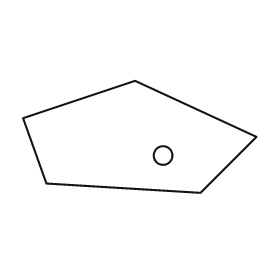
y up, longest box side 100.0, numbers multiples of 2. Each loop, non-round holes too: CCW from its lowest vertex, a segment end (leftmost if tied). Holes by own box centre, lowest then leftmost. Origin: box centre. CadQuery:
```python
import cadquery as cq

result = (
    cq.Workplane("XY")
    .moveTo(26.0, -24.0)
    .lineTo(50.0, 0.0)
    .lineTo(-2.0, 24.0)
    .lineTo(-50.0, 8.0)
    .lineTo(-40.0, -20.0)
    .close()
    .moveTo(10.0, -8.0)
    .circle(4.0)
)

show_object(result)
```